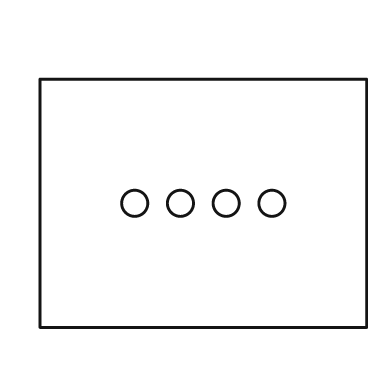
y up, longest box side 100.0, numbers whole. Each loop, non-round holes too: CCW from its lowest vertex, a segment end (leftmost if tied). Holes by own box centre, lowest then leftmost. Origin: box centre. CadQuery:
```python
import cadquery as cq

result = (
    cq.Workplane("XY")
    .moveTo(-50.0, -38.0)
    .lineTo(50.0, -38.0)
    .lineTo(50.0, 38.0)
    .lineTo(-50.0, 38.0)
    .close()
    .moveTo(-21.0, 0.0)
    .circle(4.0)
    .moveTo(-7.0, 0.0)
    .circle(4.0)
    .moveTo(7.0, 0.0)
    .circle(4.0)
    .moveTo(21.0, 0.0)
    .circle(4.0)
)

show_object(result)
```